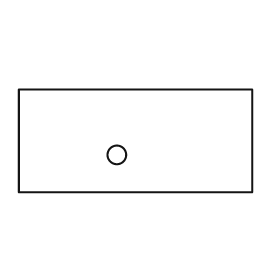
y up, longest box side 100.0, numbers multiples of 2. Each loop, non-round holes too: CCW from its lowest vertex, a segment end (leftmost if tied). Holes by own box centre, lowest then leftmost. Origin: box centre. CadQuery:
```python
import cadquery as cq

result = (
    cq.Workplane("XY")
    .moveTo(-50.0, -22.0)
    .lineTo(50.0, -22.0)
    .lineTo(50.0, 22.0)
    .lineTo(-50.0, 22.0)
    .close()
    .moveTo(-8.0, -6.0)
    .circle(4.0)
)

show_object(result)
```